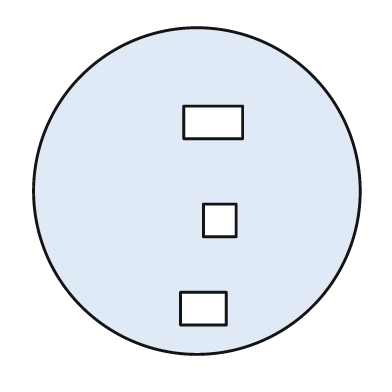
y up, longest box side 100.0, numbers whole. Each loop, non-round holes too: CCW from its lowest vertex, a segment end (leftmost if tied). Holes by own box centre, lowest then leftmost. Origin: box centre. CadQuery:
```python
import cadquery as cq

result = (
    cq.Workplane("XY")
    .moveTo(0.0, 0.0)
    .circle(50.0)
    .moveTo(-5.0, -41.0)
    .lineTo(9.0, -41.0)
    .lineTo(9.0, -31.0)
    .lineTo(-5.0, -31.0)
    .close()
    .moveTo(2.0, -14.0)
    .lineTo(12.0, -14.0)
    .lineTo(12.0, -4.0)
    .lineTo(2.0, -4.0)
    .close()
    .moveTo(-4.0, 16.0)
    .lineTo(14.0, 16.0)
    .lineTo(14.0, 26.0)
    .lineTo(-4.0, 26.0)
    .close()
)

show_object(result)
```